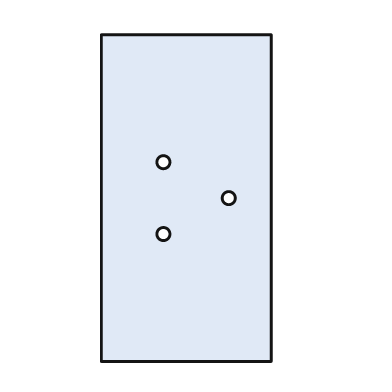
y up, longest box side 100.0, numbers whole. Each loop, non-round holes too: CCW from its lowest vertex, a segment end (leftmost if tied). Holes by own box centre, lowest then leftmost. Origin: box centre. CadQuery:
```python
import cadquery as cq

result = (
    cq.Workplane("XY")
    .moveTo(-26.0, -50.0)
    .lineTo(26.0, -50.0)
    .lineTo(26.0, 50.0)
    .lineTo(-26.0, 50.0)
    .close()
    .moveTo(-7.0, -11.0)
    .circle(2.0)
    .moveTo(13.0, 0.0)
    .circle(2.0)
    .moveTo(-7.0, 11.0)
    .circle(2.0)
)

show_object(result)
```